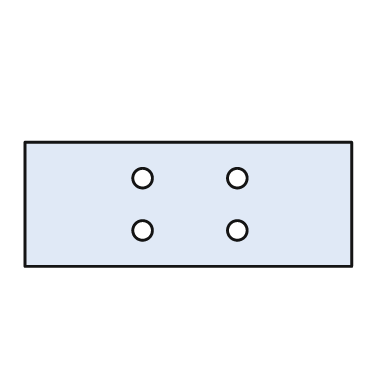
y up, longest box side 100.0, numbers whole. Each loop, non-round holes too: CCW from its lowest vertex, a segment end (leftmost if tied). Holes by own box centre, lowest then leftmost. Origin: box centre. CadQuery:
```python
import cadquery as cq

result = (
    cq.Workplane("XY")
    .moveTo(-50.0, -19.0)
    .lineTo(50.0, -19.0)
    .lineTo(50.0, 19.0)
    .lineTo(-50.0, 19.0)
    .close()
    .moveTo(-14.0, -8.0)
    .circle(3.0)
    .moveTo(15.0, -8.0)
    .circle(3.0)
    .moveTo(-14.0, 8.0)
    .circle(3.0)
    .moveTo(15.0, 8.0)
    .circle(3.0)
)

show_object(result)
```